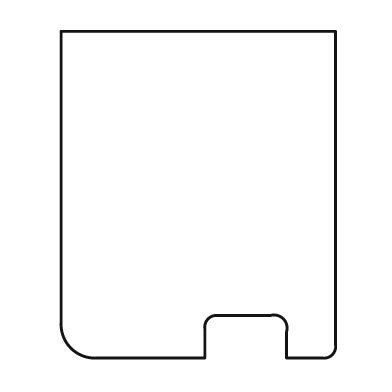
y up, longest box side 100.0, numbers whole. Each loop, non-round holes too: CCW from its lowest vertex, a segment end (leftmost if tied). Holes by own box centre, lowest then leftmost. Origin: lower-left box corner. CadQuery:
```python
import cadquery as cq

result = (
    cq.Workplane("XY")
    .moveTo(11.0, 0.0)
    .lineTo(44.0, 0.0)
    .lineTo(44.0, 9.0)
    .threePointArc((45.0, 12.0), (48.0, 13.0))
    .lineTo(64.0, 13.0)
    .threePointArc((68.0, 12.0), (69.0, 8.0))
    .lineTo(69.0, 0.0)
    .lineTo(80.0, 0.0)
    .threePointArc((83.0, 1.0), (84.0, 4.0))
    .lineTo(84.0, 100.0)
    .lineTo(0.0, 100.0)
    .lineTo(0.0, 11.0)
    .threePointArc((3.0, 3.0), (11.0, 0.0))
    .close()
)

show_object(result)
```